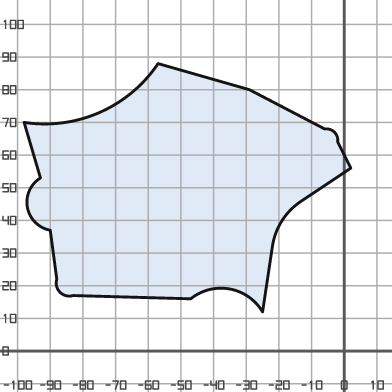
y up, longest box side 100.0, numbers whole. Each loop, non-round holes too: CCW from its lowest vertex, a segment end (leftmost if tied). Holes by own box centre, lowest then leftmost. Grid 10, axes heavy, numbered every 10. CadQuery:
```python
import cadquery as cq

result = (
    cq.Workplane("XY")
    .moveTo(-25.0, 12.0)
    .lineTo(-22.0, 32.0)
    .threePointArc((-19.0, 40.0), (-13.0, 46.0))
    .lineTo(2.0, 56.0)
    .lineTo(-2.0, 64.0)
    .threePointArc((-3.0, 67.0), (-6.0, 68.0))
    .lineTo(-29.0, 80.0)
    .lineTo(-57.0, 88.0)
    .threePointArc((-75.0, 73.0), (-98.0, 70.0))
    .lineTo(-93.0, 53.0)
    .threePointArc((-97.0, 44.0), (-90.0, 37.0))
    .lineTo(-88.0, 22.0)
    .threePointArc((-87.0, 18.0), (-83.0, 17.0))
    .lineTo(-47.0, 16.0)
    .threePointArc((-35.0, 19.0), (-25.0, 12.0))
    .close()
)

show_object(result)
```